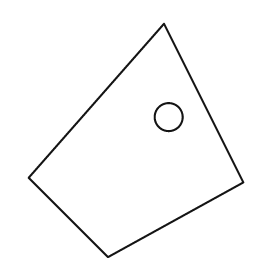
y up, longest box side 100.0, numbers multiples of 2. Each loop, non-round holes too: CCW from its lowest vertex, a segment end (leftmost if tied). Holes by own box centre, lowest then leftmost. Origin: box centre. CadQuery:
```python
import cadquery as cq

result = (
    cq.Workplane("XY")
    .moveTo(-12.0, -50.0)
    .lineTo(46.0, -18.0)
    .lineTo(12.0, 50.0)
    .lineTo(-46.0, -16.0)
    .close()
    .moveTo(14.0, 10.0)
    .circle(6.0)
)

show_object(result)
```